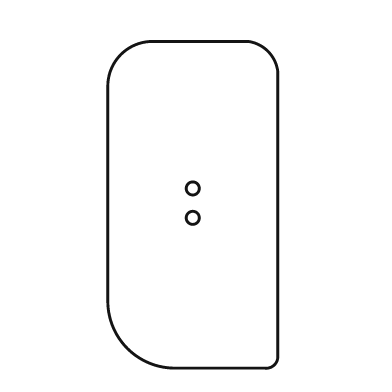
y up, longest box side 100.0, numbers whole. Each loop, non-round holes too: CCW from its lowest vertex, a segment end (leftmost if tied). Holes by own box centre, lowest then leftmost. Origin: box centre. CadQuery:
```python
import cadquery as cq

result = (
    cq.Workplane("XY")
    .moveTo(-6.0, -50.0)
    .lineTo(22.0, -50.0)
    .threePointArc((25.0, -49.0), (26.0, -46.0))
    .lineTo(26.0, 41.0)
    .threePointArc((23.0, 47.0), (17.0, 50.0))
    .lineTo(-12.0, 50.0)
    .threePointArc((-22.0, 46.0), (-26.0, 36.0))
    .lineTo(-26.0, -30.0)
    .threePointArc((-20.0, -44.0), (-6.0, -50.0))
    .close()
    .moveTo(0.0, -4.0)
    .circle(2.0)
    .moveTo(0.0, 5.0)
    .circle(2.0)
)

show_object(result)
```